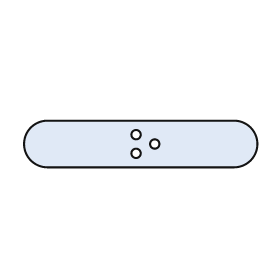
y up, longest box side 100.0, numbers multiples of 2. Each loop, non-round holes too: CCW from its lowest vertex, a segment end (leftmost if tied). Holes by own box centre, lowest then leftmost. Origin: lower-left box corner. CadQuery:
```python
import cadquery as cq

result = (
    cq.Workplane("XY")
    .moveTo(10.0, 0.0)
    .lineTo(90.0, 0.0)
    .threePointArc((100.0, 10.0), (90.0, 20.0))
    .lineTo(10.0, 20.0)
    .threePointArc((0.0, 10.0), (10.0, 0.0))
    .close()
    .moveTo(48.0, 6.0)
    .circle(2.0)
    .moveTo(56.0, 10.0)
    .circle(2.0)
    .moveTo(48.0, 14.0)
    .circle(2.0)
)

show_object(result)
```